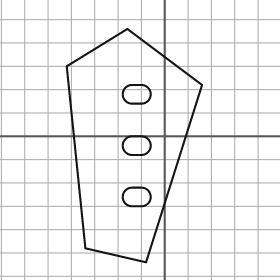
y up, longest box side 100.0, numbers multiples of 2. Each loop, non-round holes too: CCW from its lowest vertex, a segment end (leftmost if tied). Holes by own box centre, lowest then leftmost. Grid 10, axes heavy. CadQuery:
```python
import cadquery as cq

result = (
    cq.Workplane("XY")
    .moveTo(-8.0, -54.0)
    .lineTo(16.0, 22.0)
    .lineTo(-16.0, 46.0)
    .lineTo(-42.0, 30.0)
    .lineTo(-34.0, -48.0)
    .close()
    .moveTo(-14.0, -30.0)
    .lineTo(-10.0, -30.0)
    .threePointArc((-6.0, -26.0), (-10.0, -22.0))
    .lineTo(-14.0, -22.0)
    .threePointArc((-18.0, -26.0), (-14.0, -30.0))
    .close()
    .moveTo(-14.0, -8.0)
    .lineTo(-10.0, -8.0)
    .threePointArc((-6.0, -4.0), (-10.0, 0.0))
    .lineTo(-14.0, 0.0)
    .threePointArc((-18.0, -4.0), (-14.0, -8.0))
    .close()
    .moveTo(-14.0, 14.0)
    .lineTo(-10.0, 14.0)
    .threePointArc((-6.0, 18.0), (-10.0, 22.0))
    .lineTo(-14.0, 22.0)
    .threePointArc((-18.0, 18.0), (-14.0, 14.0))
    .close()
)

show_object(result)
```